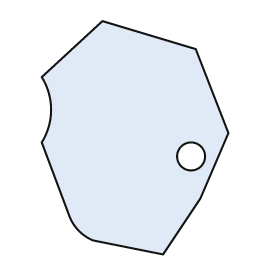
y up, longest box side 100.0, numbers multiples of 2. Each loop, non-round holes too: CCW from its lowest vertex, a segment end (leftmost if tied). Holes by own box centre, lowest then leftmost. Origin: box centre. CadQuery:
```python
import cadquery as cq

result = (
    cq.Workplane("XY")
    .moveTo(12.0, -50.0)
    .lineTo(28.0, -26.0)
    .lineTo(40.0, 2.0)
    .lineTo(26.0, 38.0)
    .lineTo(-14.0, 50.0)
    .lineTo(-40.0, 26.0)
    .threePointArc((-36.0, 12.0), (-40.0, -2.0))
    .lineTo(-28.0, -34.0)
    .threePointArc((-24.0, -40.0), (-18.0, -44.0))
    .close()
    .moveTo(24.0, -8.0)
    .circle(6.0)
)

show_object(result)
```